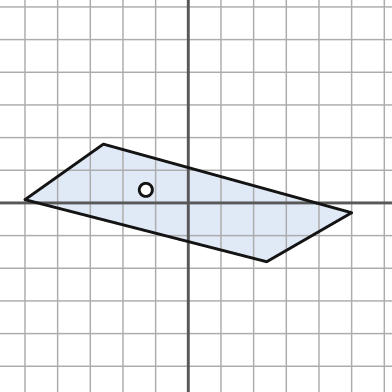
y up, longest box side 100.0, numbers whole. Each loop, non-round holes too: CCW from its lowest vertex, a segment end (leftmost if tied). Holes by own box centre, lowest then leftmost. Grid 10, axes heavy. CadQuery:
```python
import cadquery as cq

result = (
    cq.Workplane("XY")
    .moveTo(24.0, -18.0)
    .lineTo(50.0, -3.0)
    .lineTo(-26.0, 18.0)
    .lineTo(-50.0, 1.0)
    .close()
    .moveTo(-13.0, 4.0)
    .circle(2.0)
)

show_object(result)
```